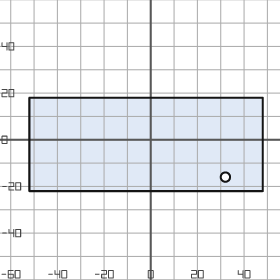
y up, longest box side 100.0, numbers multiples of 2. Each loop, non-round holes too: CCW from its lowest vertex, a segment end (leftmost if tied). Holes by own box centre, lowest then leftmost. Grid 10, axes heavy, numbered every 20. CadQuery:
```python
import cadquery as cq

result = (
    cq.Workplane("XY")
    .moveTo(-52.0, -22.0)
    .lineTo(48.0, -22.0)
    .lineTo(48.0, 18.0)
    .lineTo(-52.0, 18.0)
    .close()
    .moveTo(32.0, -16.0)
    .circle(2.0)
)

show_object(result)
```